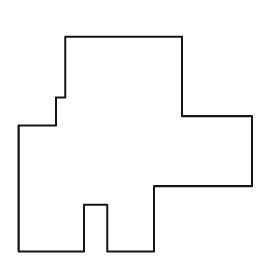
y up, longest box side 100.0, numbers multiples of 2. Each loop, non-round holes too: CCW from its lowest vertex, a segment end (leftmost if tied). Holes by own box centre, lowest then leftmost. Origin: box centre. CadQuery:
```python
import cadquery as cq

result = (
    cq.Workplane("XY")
    .moveTo(-50.0, -46.0)
    .lineTo(-22.0, -46.0)
    .lineTo(-22.0, -26.0)
    .lineTo(-12.0, -26.0)
    .lineTo(-12.0, -46.0)
    .lineTo(8.0, -46.0)
    .lineTo(8.0, -18.0)
    .lineTo(50.0, -18.0)
    .lineTo(50.0, 12.0)
    .lineTo(20.0, 12.0)
    .lineTo(20.0, 46.0)
    .lineTo(-30.0, 46.0)
    .lineTo(-30.0, 20.0)
    .lineTo(-34.0, 20.0)
    .lineTo(-34.0, 8.0)
    .lineTo(-50.0, 8.0)
    .close()
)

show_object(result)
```